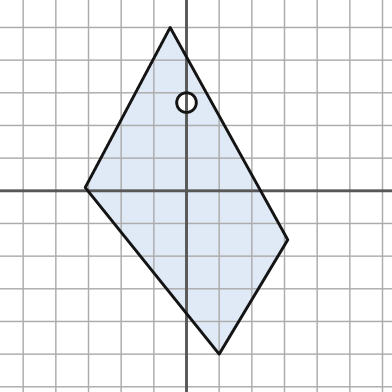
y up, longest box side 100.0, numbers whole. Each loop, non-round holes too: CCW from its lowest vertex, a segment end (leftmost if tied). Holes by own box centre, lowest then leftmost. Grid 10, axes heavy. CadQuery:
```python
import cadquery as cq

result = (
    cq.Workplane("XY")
    .moveTo(10.0, -50.0)
    .lineTo(31.0, -15.0)
    .lineTo(-5.0, 50.0)
    .lineTo(-31.0, 1.0)
    .close()
    .moveTo(0.0, 27.0)
    .circle(3.0)
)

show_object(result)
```